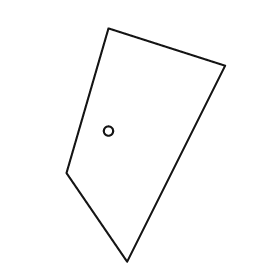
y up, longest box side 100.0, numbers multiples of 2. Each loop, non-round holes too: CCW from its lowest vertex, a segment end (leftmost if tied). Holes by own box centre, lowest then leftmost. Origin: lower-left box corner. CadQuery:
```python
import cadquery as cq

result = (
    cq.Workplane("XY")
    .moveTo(26.0, 0.0)
    .lineTo(68.0, 84.0)
    .lineTo(18.0, 100.0)
    .lineTo(0.0, 38.0)
    .close()
    .moveTo(18.0, 56.0)
    .circle(2.0)
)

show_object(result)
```